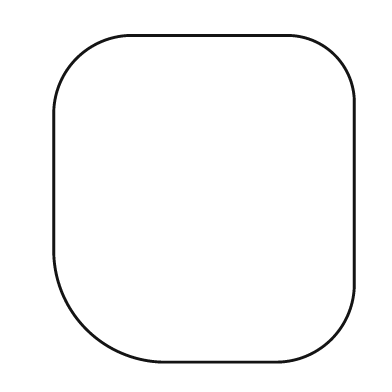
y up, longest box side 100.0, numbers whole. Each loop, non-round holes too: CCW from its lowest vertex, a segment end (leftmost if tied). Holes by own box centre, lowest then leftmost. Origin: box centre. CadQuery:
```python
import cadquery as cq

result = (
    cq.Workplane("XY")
    .moveTo(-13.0, -50.0)
    .lineTo(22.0, -50.0)
    .threePointArc((39.0, -43.0), (46.0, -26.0))
    .lineTo(46.0, 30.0)
    .threePointArc((40.0, 44.0), (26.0, 50.0))
    .lineTo(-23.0, 50.0)
    .threePointArc((-39.0, 43.0), (-46.0, 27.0))
    .lineTo(-46.0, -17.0)
    .threePointArc((-36.0, -40.0), (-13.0, -50.0))
    .close()
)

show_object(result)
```